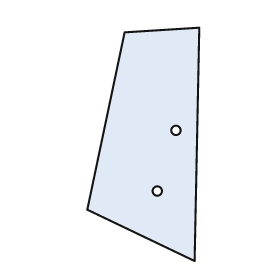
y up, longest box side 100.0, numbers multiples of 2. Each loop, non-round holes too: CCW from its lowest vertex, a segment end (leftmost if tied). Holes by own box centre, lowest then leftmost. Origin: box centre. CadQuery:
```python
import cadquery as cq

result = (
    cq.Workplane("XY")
    .moveTo(22.0, -50.0)
    .lineTo(24.0, 50.0)
    .lineTo(-8.0, 48.0)
    .lineTo(-24.0, -28.0)
    .close()
    .moveTo(6.0, -20.0)
    .circle(2.0)
    .moveTo(14.0, 6.0)
    .circle(2.0)
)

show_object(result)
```